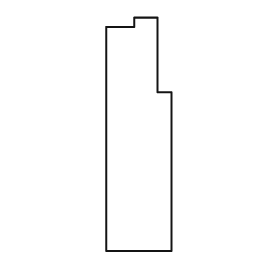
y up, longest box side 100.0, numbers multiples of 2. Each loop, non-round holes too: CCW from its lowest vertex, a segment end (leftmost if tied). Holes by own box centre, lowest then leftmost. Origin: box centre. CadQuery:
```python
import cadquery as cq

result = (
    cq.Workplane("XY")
    .moveTo(-14.0, -50.0)
    .lineTo(14.0, -50.0)
    .lineTo(14.0, 18.0)
    .lineTo(8.0, 18.0)
    .lineTo(8.0, 50.0)
    .lineTo(-2.0, 50.0)
    .lineTo(-2.0, 46.0)
    .lineTo(-14.0, 46.0)
    .close()
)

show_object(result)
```